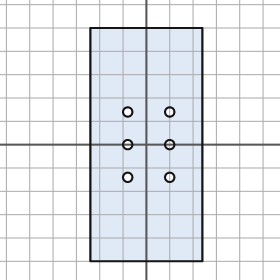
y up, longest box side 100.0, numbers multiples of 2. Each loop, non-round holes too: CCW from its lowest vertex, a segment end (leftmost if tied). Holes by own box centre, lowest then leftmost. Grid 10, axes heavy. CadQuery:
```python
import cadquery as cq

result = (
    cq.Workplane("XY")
    .moveTo(-24.0, -50.0)
    .lineTo(24.0, -50.0)
    .lineTo(24.0, 50.0)
    .lineTo(-24.0, 50.0)
    .close()
    .moveTo(-8.0, -14.0)
    .circle(2.0)
    .moveTo(10.0, -14.0)
    .circle(2.0)
    .moveTo(-8.0, 0.0)
    .circle(2.0)
    .moveTo(10.0, 0.0)
    .circle(2.0)
    .moveTo(-8.0, 14.0)
    .circle(2.0)
    .moveTo(10.0, 14.0)
    .circle(2.0)
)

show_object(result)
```